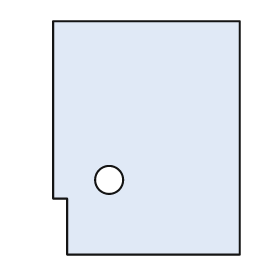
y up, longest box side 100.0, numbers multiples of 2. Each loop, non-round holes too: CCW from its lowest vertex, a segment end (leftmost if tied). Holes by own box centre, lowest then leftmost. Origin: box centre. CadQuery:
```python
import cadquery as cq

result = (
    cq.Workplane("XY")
    .moveTo(-34.0, -50.0)
    .lineTo(40.0, -50.0)
    .lineTo(40.0, 50.0)
    .lineTo(-40.0, 50.0)
    .lineTo(-40.0, -26.0)
    .lineTo(-34.0, -26.0)
    .close()
    .moveTo(-16.0, -18.0)
    .circle(6.0)
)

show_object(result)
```